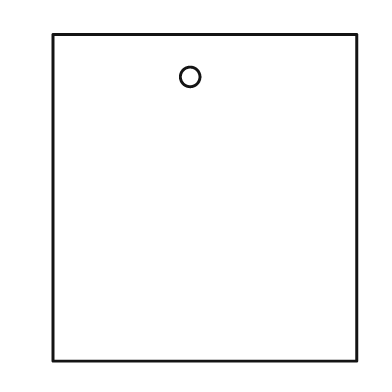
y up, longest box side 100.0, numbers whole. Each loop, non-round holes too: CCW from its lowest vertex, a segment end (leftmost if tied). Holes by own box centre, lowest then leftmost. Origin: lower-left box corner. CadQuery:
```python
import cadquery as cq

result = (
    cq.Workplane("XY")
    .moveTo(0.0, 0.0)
    .lineTo(93.0, 0.0)
    .lineTo(93.0, 100.0)
    .lineTo(0.0, 100.0)
    .close()
    .moveTo(42.0, 87.0)
    .circle(3.0)
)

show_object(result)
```